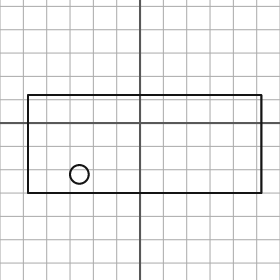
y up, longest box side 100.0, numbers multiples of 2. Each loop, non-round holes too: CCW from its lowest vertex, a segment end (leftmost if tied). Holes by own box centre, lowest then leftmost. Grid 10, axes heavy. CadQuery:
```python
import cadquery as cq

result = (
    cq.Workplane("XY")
    .moveTo(-48.0, -30.0)
    .lineTo(52.0, -30.0)
    .lineTo(52.0, 12.0)
    .lineTo(-48.0, 12.0)
    .close()
    .moveTo(-26.0, -22.0)
    .circle(4.0)
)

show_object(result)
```